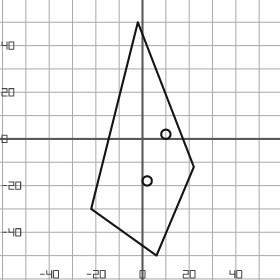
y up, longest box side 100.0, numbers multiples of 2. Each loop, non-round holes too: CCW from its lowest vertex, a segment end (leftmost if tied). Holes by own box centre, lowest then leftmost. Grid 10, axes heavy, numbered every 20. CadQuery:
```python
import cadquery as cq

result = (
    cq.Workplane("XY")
    .moveTo(6.0, -50.0)
    .lineTo(22.0, -12.0)
    .lineTo(-2.0, 50.0)
    .lineTo(-22.0, -30.0)
    .close()
    .moveTo(2.0, -18.0)
    .circle(2.0)
    .moveTo(10.0, 2.0)
    .circle(2.0)
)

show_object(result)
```